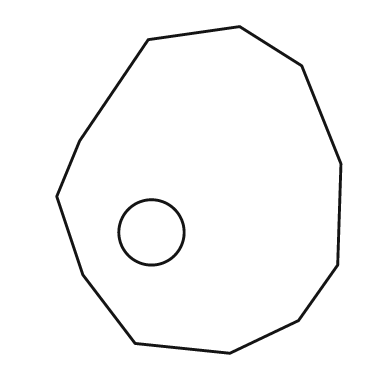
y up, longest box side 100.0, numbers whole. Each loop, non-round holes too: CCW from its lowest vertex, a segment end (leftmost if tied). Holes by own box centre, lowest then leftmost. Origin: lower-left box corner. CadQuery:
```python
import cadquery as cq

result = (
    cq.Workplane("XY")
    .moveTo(53.0, 0.0)
    .lineTo(74.0, 10.0)
    .lineTo(86.0, 27.0)
    .lineTo(87.0, 58.0)
    .lineTo(75.0, 88.0)
    .lineTo(56.0, 100.0)
    .lineTo(28.0, 96.0)
    .lineTo(7.0, 65.0)
    .lineTo(0.0, 48.0)
    .lineTo(8.0, 24.0)
    .lineTo(24.0, 3.0)
    .close()
    .moveTo(29.0, 37.0)
    .circle(10.0)
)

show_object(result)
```